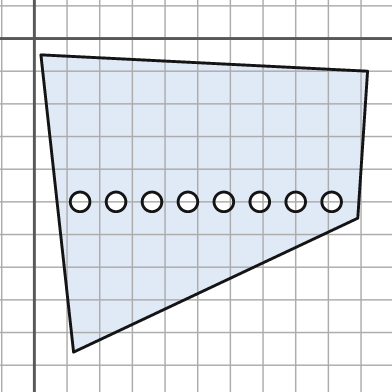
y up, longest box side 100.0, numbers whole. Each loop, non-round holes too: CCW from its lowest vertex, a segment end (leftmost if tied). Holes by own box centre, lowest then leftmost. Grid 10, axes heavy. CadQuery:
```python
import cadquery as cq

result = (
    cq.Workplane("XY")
    .moveTo(12.0, -96.0)
    .lineTo(99.0, -55.0)
    .lineTo(102.0, -10.0)
    .lineTo(2.0, -5.0)
    .close()
    .moveTo(14.0, -50.0)
    .circle(3.0)
    .moveTo(25.0, -50.0)
    .circle(3.0)
    .moveTo(36.0, -50.0)
    .circle(3.0)
    .moveTo(47.0, -50.0)
    .circle(3.0)
    .moveTo(58.0, -50.0)
    .circle(3.0)
    .moveTo(69.0, -50.0)
    .circle(3.0)
    .moveTo(80.0, -50.0)
    .circle(3.0)
    .moveTo(91.0, -50.0)
    .circle(3.0)
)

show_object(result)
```